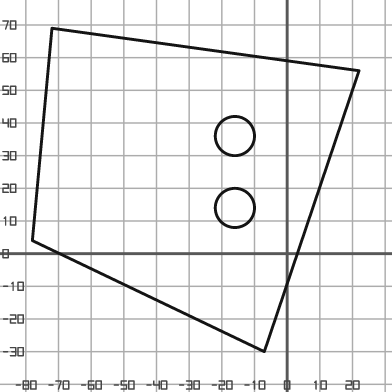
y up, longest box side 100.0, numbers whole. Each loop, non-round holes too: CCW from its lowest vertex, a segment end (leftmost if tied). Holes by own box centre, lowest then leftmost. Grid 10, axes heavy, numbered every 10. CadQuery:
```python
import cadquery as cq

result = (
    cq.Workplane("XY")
    .moveTo(-7.0, -30.0)
    .lineTo(22.0, 56.0)
    .lineTo(-72.0, 69.0)
    .lineTo(-78.0, 4.0)
    .close()
    .moveTo(-16.0, 14.0)
    .circle(6.0)
    .moveTo(-16.0, 36.0)
    .circle(6.0)
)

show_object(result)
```